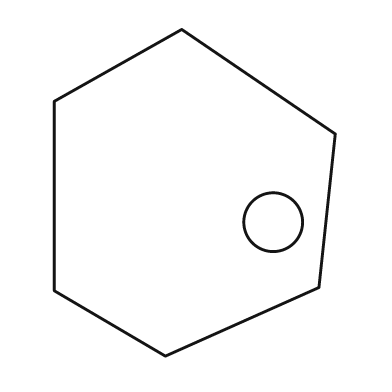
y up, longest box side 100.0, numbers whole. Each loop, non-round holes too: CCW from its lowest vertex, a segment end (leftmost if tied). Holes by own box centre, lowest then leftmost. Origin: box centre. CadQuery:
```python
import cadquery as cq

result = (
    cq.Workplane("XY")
    .moveTo(-9.0, -50.0)
    .lineTo(38.0, -29.0)
    .lineTo(43.0, 18.0)
    .lineTo(-4.0, 50.0)
    .lineTo(-43.0, 28.0)
    .lineTo(-43.0, -30.0)
    .close()
    .moveTo(24.0, -9.0)
    .circle(9.0)
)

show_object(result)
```